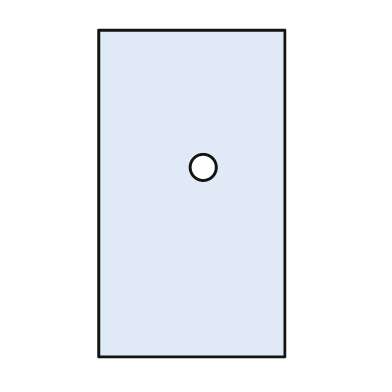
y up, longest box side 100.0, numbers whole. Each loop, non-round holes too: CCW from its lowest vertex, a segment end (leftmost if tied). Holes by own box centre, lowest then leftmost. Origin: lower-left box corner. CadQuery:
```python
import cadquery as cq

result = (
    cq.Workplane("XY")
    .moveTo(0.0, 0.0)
    .lineTo(57.0, 0.0)
    .lineTo(57.0, 100.0)
    .lineTo(0.0, 100.0)
    .close()
    .moveTo(32.0, 58.0)
    .circle(4.0)
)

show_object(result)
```